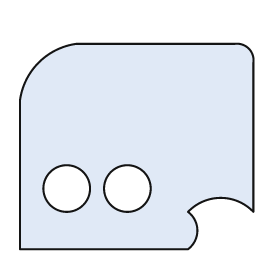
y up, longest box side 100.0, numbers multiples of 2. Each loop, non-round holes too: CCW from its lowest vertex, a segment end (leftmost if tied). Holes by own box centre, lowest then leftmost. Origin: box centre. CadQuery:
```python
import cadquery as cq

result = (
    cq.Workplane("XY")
    .moveTo(-50.0, -44.0)
    .lineTo(22.0, -44.0)
    .threePointArc((26.0, -36.0), (22.0, -28.0))
    .threePointArc((36.0, -22.0), (50.0, -28.0))
    .lineTo(50.0, 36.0)
    .threePointArc((48.0, 42.0), (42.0, 44.0))
    .lineTo(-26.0, 44.0)
    .threePointArc((-42.0, 36.0), (-50.0, 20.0))
    .close()
    .moveTo(-30.0, -18.0)
    .circle(10.0)
    .moveTo(-4.0, -18.0)
    .circle(10.0)
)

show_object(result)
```